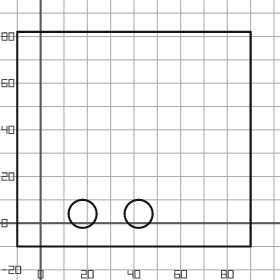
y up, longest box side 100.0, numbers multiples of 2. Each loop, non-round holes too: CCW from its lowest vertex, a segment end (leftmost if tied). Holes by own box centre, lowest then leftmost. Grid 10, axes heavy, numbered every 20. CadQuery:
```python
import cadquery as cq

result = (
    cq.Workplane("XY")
    .moveTo(-10.0, -10.0)
    .lineTo(90.0, -10.0)
    .lineTo(90.0, 82.0)
    .lineTo(-10.0, 82.0)
    .close()
    .moveTo(18.0, 4.0)
    .circle(6.0)
    .moveTo(42.0, 4.0)
    .circle(6.0)
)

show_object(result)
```